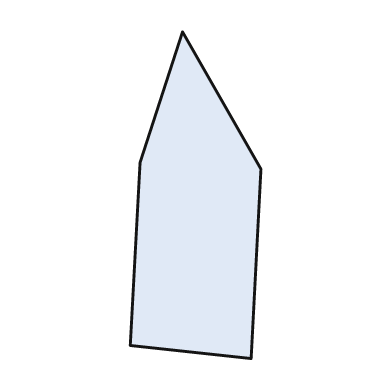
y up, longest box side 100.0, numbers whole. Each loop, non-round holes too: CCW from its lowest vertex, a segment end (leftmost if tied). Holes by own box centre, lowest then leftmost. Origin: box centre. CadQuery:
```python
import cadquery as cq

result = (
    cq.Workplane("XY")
    .moveTo(17.0, -50.0)
    .lineTo(20.0, 8.0)
    .lineTo(-4.0, 50.0)
    .lineTo(-17.0, 10.0)
    .lineTo(-20.0, -46.0)
    .close()
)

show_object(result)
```